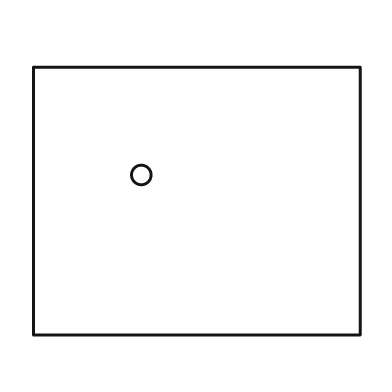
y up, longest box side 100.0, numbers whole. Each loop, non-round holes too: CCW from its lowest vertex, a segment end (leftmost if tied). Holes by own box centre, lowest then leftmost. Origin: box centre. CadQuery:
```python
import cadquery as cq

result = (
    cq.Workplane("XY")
    .moveTo(-50.0, -41.0)
    .lineTo(50.0, -41.0)
    .lineTo(50.0, 41.0)
    .lineTo(-50.0, 41.0)
    .close()
    .moveTo(-17.0, 8.0)
    .circle(3.0)
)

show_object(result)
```